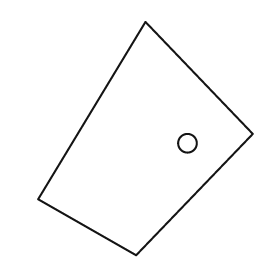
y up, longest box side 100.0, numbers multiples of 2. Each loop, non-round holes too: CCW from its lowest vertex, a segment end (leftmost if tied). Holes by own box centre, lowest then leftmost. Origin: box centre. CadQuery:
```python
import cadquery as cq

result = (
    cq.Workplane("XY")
    .moveTo(-4.0, -50.0)
    .lineTo(46.0, 2.0)
    .lineTo(0.0, 50.0)
    .lineTo(-46.0, -26.0)
    .close()
    .moveTo(18.0, -2.0)
    .circle(4.0)
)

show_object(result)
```